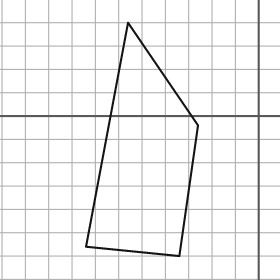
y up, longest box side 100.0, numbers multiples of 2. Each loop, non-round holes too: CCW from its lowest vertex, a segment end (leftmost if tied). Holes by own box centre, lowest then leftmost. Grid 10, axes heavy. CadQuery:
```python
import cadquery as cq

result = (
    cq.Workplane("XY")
    .moveTo(-34.0, -60.0)
    .lineTo(-26.0, -4.0)
    .lineTo(-56.0, 40.0)
    .lineTo(-74.0, -56.0)
    .close()
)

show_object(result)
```